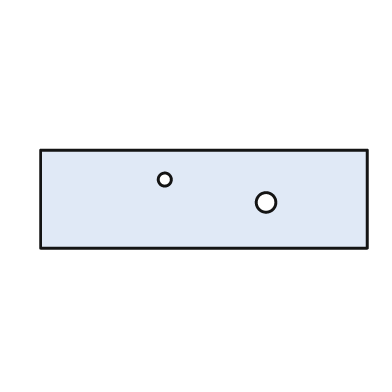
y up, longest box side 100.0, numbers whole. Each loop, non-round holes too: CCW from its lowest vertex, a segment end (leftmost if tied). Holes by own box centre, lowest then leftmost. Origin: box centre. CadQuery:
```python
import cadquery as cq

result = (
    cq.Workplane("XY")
    .moveTo(-50.0, -15.0)
    .lineTo(50.0, -15.0)
    .lineTo(50.0, 15.0)
    .lineTo(-50.0, 15.0)
    .close()
    .moveTo(19.0, -1.0)
    .circle(3.0)
    .moveTo(-12.0, 6.0)
    .circle(2.0)
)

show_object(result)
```